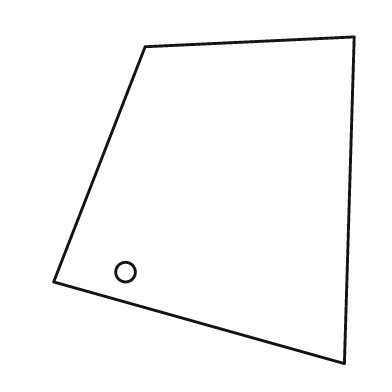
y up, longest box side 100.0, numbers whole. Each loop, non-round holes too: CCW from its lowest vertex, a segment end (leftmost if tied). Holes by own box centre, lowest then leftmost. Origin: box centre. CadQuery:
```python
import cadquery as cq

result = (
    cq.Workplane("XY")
    .moveTo(43.0, -50.0)
    .lineTo(46.0, 50.0)
    .lineTo(-18.0, 47.0)
    .lineTo(-46.0, -25.0)
    .close()
    .moveTo(-24.0, -22.0)
    .circle(3.0)
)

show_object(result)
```